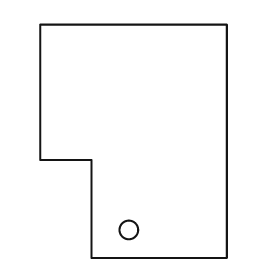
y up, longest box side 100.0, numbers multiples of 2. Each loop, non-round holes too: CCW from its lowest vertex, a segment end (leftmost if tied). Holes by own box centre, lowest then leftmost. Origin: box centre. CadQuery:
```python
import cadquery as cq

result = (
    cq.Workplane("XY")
    .moveTo(-18.0, -50.0)
    .lineTo(40.0, -50.0)
    .lineTo(40.0, 50.0)
    .lineTo(-40.0, 50.0)
    .lineTo(-40.0, -8.0)
    .lineTo(-18.0, -8.0)
    .close()
    .moveTo(-2.0, -38.0)
    .circle(4.0)
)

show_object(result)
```